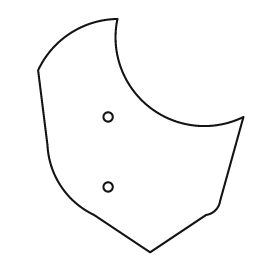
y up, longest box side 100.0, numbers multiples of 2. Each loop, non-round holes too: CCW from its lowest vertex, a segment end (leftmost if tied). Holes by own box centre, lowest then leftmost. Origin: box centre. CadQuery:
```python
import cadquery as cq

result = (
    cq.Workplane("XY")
    .moveTo(4.0, -50.0)
    .lineTo(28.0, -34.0)
    .threePointArc((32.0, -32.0), (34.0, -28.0))
    .lineTo(44.0, 8.0)
    .threePointArc((4.0, 12.0), (-10.0, 50.0))
    .threePointArc((-30.0, 44.0), (-44.0, 28.0))
    .lineTo(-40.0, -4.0)
    .threePointArc((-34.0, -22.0), (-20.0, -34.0))
    .close()
    .moveTo(-14.0, -22.0)
    .circle(2.0)
    .moveTo(-14.0, 8.0)
    .circle(2.0)
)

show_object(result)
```